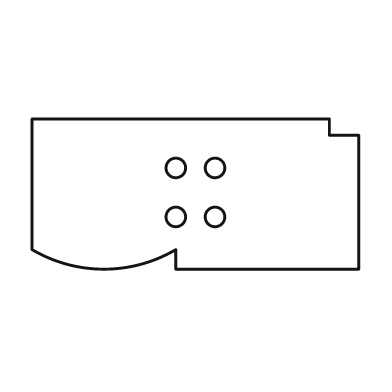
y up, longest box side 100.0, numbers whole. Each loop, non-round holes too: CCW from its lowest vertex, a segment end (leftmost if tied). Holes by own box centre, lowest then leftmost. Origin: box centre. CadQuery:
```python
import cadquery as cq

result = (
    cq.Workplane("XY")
    .moveTo(-6.0, -23.0)
    .lineTo(50.0, -23.0)
    .lineTo(50.0, 18.0)
    .lineTo(41.0, 18.0)
    .lineTo(41.0, 23.0)
    .lineTo(-50.0, 23.0)
    .lineTo(-50.0, -17.0)
    .threePointArc((-28.0, -23.0), (-6.0, -17.0))
    .close()
    .moveTo(-6.0, -7.0)
    .circle(3.0)
    .moveTo(6.0, -7.0)
    .circle(3.0)
    .moveTo(-6.0, 8.0)
    .circle(3.0)
    .moveTo(6.0, 8.0)
    .circle(3.0)
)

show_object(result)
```